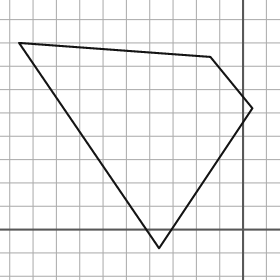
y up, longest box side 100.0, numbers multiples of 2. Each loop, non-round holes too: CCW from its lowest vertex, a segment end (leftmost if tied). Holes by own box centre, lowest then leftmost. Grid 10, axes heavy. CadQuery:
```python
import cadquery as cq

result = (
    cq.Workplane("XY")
    .moveTo(-36.0, -8.0)
    .lineTo(4.0, 52.0)
    .lineTo(-14.0, 74.0)
    .lineTo(-96.0, 80.0)
    .close()
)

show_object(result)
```